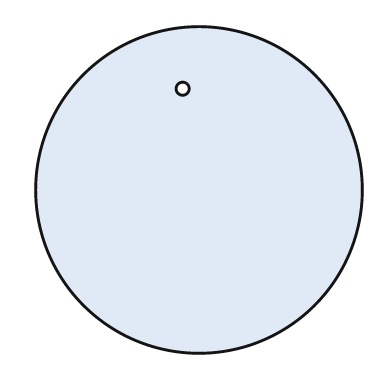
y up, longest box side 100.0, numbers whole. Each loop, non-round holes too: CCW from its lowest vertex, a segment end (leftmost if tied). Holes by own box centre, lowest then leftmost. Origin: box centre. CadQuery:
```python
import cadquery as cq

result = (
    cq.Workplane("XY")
    .moveTo(0.0, 0.0)
    .circle(50.0)
    .moveTo(-5.0, 31.0)
    .circle(2.0)
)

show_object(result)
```